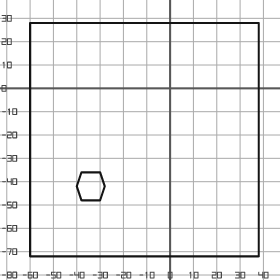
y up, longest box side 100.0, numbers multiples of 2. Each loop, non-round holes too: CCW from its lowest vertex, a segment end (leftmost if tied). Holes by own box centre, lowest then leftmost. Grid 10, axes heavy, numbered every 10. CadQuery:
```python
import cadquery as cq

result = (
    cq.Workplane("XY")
    .moveTo(-60.0, -72.0)
    .lineTo(38.0, -72.0)
    .lineTo(38.0, 28.0)
    .lineTo(-60.0, 28.0)
    .close()
    .moveTo(-38.0, -48.0)
    .lineTo(-30.0, -48.0)
    .lineTo(-28.0, -42.0)
    .lineTo(-30.0, -36.0)
    .lineTo(-38.0, -36.0)
    .lineTo(-40.0, -42.0)
    .close()
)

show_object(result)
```